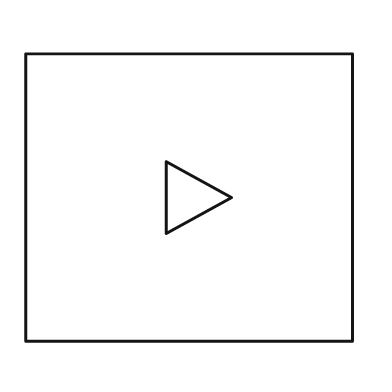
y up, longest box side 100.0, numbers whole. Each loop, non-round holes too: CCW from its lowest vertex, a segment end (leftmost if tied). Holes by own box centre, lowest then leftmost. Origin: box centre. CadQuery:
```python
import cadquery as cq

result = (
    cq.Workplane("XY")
    .moveTo(-50.0, -44.0)
    .lineTo(50.0, -44.0)
    .lineTo(50.0, 44.0)
    .lineTo(-50.0, 44.0)
    .close()
    .moveTo(-7.0, -11.0)
    .lineTo(13.0, 0.0)
    .lineTo(-7.0, 11.0)
    .close()
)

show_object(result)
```